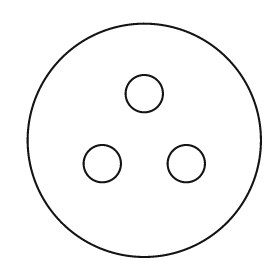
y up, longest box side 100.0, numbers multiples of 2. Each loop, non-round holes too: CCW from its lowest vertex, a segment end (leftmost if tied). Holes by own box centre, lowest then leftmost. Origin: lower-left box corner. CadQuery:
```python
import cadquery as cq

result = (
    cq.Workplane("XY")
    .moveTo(50.0, 50.0)
    .circle(50.0)
    .moveTo(32.0, 40.0)
    .circle(8.0)
    .moveTo(68.0, 40.0)
    .circle(8.0)
    .moveTo(50.0, 70.0)
    .circle(8.0)
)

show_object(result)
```